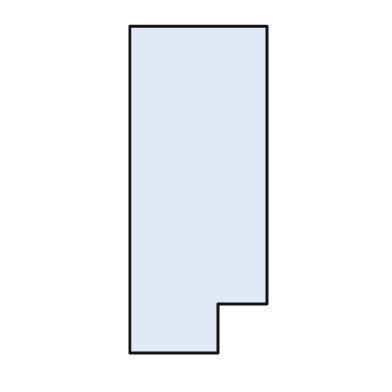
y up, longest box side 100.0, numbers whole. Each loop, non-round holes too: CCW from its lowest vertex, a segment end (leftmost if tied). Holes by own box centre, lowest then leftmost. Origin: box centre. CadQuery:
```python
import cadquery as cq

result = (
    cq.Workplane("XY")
    .moveTo(-21.0, -50.0)
    .lineTo(6.0, -50.0)
    .lineTo(6.0, -35.0)
    .lineTo(21.0, -35.0)
    .lineTo(21.0, 50.0)
    .lineTo(-21.0, 50.0)
    .close()
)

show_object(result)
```